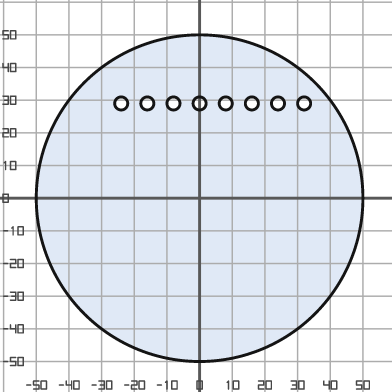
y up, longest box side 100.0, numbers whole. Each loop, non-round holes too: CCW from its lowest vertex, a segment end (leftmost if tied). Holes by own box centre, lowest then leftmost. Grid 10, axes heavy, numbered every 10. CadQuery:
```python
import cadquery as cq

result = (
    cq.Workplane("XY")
    .moveTo(0.0, 0.0)
    .circle(50.0)
    .moveTo(-24.0, 29.0)
    .circle(2.0)
    .moveTo(-16.0, 29.0)
    .circle(2.0)
    .moveTo(-8.0, 29.0)
    .circle(2.0)
    .moveTo(0.0, 29.0)
    .circle(2.0)
    .moveTo(8.0, 29.0)
    .circle(2.0)
    .moveTo(16.0, 29.0)
    .circle(2.0)
    .moveTo(24.0, 29.0)
    .circle(2.0)
    .moveTo(32.0, 29.0)
    .circle(2.0)
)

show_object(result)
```